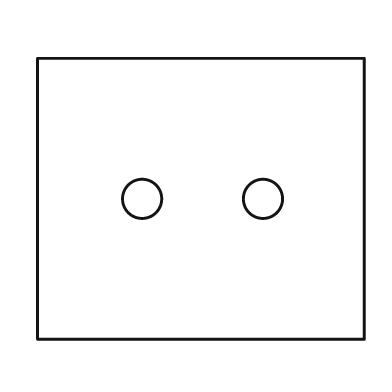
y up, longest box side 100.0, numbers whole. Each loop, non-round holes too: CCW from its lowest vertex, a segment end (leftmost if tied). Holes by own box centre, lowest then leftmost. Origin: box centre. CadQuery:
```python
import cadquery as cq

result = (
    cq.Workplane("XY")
    .moveTo(-50.0, -43.0)
    .lineTo(50.0, -43.0)
    .lineTo(50.0, 43.0)
    .lineTo(-50.0, 43.0)
    .close()
    .moveTo(-18.0, 0.0)
    .circle(6.0)
    .moveTo(19.0, 0.0)
    .circle(6.0)
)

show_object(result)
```